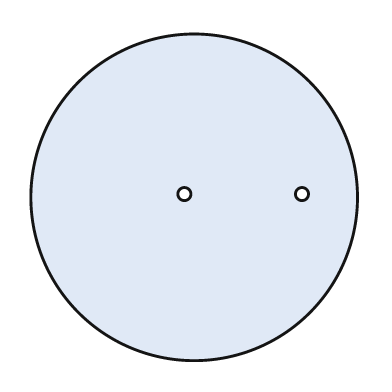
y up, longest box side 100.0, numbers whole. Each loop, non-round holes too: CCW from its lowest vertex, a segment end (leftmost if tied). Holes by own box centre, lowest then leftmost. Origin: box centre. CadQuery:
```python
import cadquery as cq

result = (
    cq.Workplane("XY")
    .moveTo(0.0, 0.0)
    .circle(50.0)
    .moveTo(-3.0, 1.0)
    .circle(2.0)
    .moveTo(33.0, 1.0)
    .circle(2.0)
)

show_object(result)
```